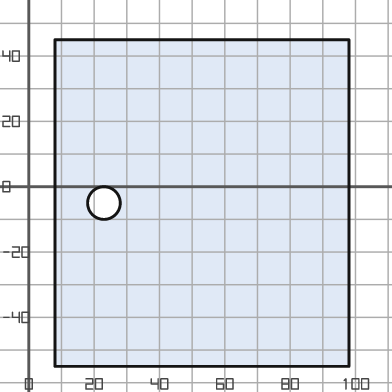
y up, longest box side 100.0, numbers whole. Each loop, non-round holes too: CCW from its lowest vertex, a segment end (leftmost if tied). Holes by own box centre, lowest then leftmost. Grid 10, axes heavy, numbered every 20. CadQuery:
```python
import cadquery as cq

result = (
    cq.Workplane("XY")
    .moveTo(8.0, -55.0)
    .lineTo(98.0, -55.0)
    .lineTo(98.0, 45.0)
    .lineTo(8.0, 45.0)
    .close()
    .moveTo(23.0, -5.0)
    .circle(5.0)
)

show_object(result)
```